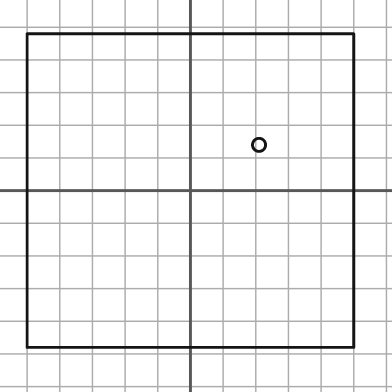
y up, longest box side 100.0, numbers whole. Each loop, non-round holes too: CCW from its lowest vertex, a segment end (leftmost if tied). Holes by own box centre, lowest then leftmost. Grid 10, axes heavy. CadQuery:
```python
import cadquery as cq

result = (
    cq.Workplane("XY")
    .moveTo(-50.0, -48.0)
    .lineTo(50.0, -48.0)
    .lineTo(50.0, 48.0)
    .lineTo(-50.0, 48.0)
    .close()
    .moveTo(21.0, 14.0)
    .circle(2.0)
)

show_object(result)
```